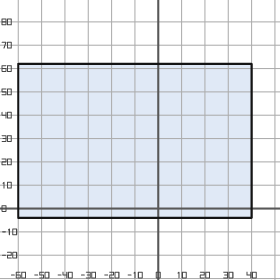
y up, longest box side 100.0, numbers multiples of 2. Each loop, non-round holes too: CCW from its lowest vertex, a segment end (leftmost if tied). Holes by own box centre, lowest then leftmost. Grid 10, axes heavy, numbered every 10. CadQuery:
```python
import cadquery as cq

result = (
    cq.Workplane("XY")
    .moveTo(-60.0, -4.0)
    .lineTo(40.0, -4.0)
    .lineTo(40.0, 62.0)
    .lineTo(-60.0, 62.0)
    .close()
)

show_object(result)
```